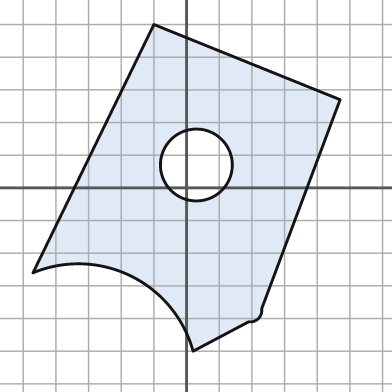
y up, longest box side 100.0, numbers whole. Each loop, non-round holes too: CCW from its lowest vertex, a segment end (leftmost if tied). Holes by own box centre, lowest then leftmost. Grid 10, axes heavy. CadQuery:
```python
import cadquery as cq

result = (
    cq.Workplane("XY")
    .moveTo(2.0, -50.0)
    .lineTo(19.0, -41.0)
    .threePointArc((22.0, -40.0), (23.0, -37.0))
    .lineTo(47.0, 27.0)
    .lineTo(-10.0, 50.0)
    .lineTo(-47.0, -26.0)
    .threePointArc((-17.0, -27.0), (2.0, -50.0))
    .close()
    .moveTo(3.0, 7.0)
    .circle(11.0)
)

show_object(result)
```